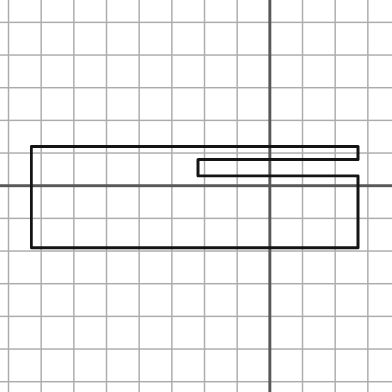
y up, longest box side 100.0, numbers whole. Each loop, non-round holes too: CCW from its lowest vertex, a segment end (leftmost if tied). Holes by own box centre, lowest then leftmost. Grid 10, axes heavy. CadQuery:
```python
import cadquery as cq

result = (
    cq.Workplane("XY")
    .moveTo(-73.0, -19.0)
    .lineTo(27.0, -19.0)
    .lineTo(27.0, 3.0)
    .lineTo(-22.0, 3.0)
    .lineTo(-22.0, 8.0)
    .lineTo(27.0, 8.0)
    .lineTo(27.0, 12.0)
    .lineTo(-73.0, 12.0)
    .close()
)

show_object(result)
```